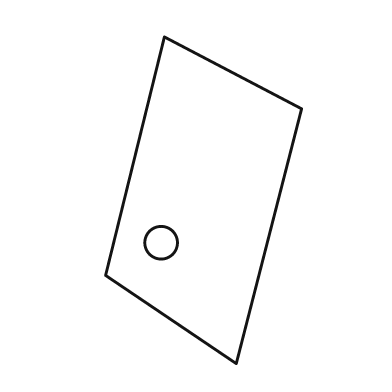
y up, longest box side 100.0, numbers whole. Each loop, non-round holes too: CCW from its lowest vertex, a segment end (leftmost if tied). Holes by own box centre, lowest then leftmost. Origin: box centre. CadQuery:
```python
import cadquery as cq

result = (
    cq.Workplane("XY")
    .moveTo(10.0, -50.0)
    .lineTo(30.0, 28.0)
    .lineTo(-12.0, 50.0)
    .lineTo(-30.0, -23.0)
    .close()
    .moveTo(-13.0, -13.0)
    .circle(5.0)
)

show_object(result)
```